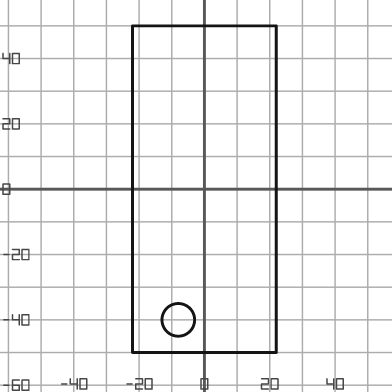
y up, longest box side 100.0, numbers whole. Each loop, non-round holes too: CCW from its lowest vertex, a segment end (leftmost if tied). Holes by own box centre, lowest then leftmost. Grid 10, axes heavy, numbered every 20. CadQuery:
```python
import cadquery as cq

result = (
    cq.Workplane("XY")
    .moveTo(-22.0, -50.0)
    .lineTo(22.0, -50.0)
    .lineTo(22.0, 50.0)
    .lineTo(-22.0, 50.0)
    .close()
    .moveTo(-8.0, -40.0)
    .circle(5.0)
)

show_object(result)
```